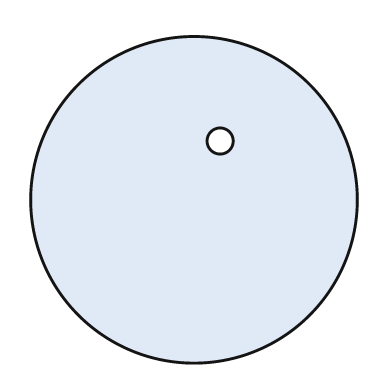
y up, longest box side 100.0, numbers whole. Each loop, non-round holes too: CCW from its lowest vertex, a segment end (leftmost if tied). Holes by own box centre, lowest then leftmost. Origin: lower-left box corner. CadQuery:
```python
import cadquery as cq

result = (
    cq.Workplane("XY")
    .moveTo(50.0, 50.0)
    .circle(50.0)
    .moveTo(58.0, 68.0)
    .circle(4.0)
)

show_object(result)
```